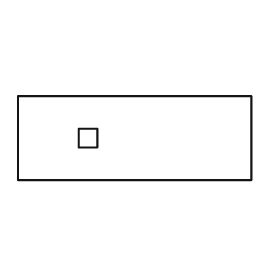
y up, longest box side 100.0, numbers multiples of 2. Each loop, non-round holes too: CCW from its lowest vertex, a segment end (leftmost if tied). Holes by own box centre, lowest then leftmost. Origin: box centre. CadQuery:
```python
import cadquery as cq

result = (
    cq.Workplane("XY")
    .moveTo(-50.0, -18.0)
    .lineTo(50.0, -18.0)
    .lineTo(50.0, 18.0)
    .lineTo(-50.0, 18.0)
    .close()
    .moveTo(-24.0, -4.0)
    .lineTo(-16.0, -4.0)
    .lineTo(-16.0, 4.0)
    .lineTo(-24.0, 4.0)
    .close()
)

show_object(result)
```